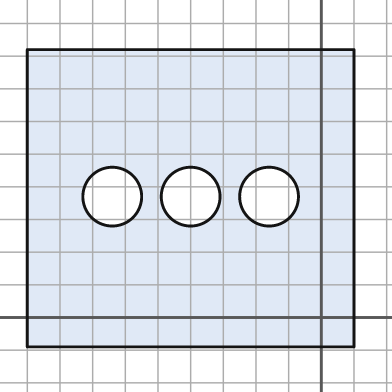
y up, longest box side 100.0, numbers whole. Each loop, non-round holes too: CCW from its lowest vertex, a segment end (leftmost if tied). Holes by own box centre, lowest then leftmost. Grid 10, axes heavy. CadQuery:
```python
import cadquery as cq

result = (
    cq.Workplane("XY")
    .moveTo(-90.0, -9.0)
    .lineTo(10.0, -9.0)
    .lineTo(10.0, 82.0)
    .lineTo(-90.0, 82.0)
    .close()
    .moveTo(-64.0, 37.0)
    .circle(9.0)
    .moveTo(-40.0, 37.0)
    .circle(9.0)
    .moveTo(-16.0, 37.0)
    .circle(9.0)
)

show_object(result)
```